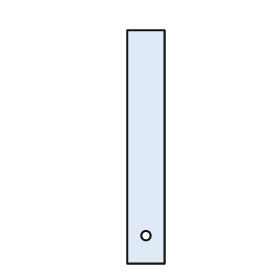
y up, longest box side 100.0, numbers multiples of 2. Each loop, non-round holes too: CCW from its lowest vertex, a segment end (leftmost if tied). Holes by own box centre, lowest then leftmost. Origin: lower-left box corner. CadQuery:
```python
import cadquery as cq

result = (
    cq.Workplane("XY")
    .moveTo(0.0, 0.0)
    .lineTo(16.0, 0.0)
    .lineTo(16.0, 100.0)
    .lineTo(0.0, 100.0)
    .close()
    .moveTo(8.0, 12.0)
    .circle(2.0)
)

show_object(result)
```